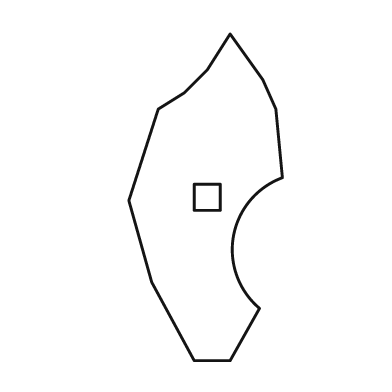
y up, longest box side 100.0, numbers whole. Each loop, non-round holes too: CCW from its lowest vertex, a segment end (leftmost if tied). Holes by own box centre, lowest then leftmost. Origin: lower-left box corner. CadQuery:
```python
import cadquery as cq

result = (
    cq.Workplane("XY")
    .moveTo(20.0, 0.0)
    .lineTo(31.0, 0.0)
    .lineTo(40.0, 16.0)
    .threePointArc((32.0, 38.0), (47.0, 56.0))
    .lineTo(45.0, 77.0)
    .lineTo(41.0, 86.0)
    .lineTo(31.0, 100.0)
    .lineTo(24.0, 89.0)
    .lineTo(17.0, 82.0)
    .lineTo(9.0, 77.0)
    .lineTo(0.0, 49.0)
    .lineTo(7.0, 24.0)
    .close()
    .moveTo(20.0, 46.0)
    .lineTo(28.0, 46.0)
    .lineTo(28.0, 54.0)
    .lineTo(20.0, 54.0)
    .close()
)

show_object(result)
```